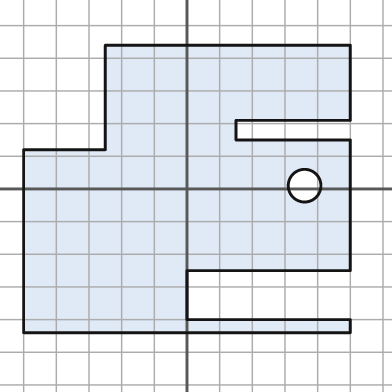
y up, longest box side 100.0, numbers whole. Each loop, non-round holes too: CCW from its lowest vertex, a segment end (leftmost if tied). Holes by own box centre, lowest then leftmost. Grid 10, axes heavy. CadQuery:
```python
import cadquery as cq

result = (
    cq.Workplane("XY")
    .moveTo(-50.0, -44.0)
    .lineTo(50.0, -44.0)
    .lineTo(50.0, -40.0)
    .lineTo(0.0, -40.0)
    .lineTo(0.0, -25.0)
    .lineTo(50.0, -25.0)
    .lineTo(50.0, 15.0)
    .lineTo(15.0, 15.0)
    .lineTo(15.0, 21.0)
    .lineTo(50.0, 21.0)
    .lineTo(50.0, 44.0)
    .lineTo(-25.0, 44.0)
    .lineTo(-25.0, 12.0)
    .lineTo(-50.0, 12.0)
    .close()
    .moveTo(36.0, 1.0)
    .circle(5.0)
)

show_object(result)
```